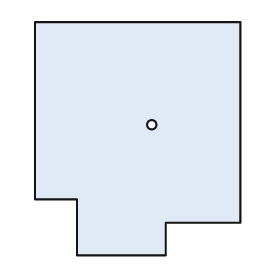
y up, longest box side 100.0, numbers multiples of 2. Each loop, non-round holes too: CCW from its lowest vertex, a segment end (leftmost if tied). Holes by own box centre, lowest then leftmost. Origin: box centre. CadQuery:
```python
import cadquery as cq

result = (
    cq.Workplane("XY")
    .moveTo(-26.0, -50.0)
    .lineTo(12.0, -50.0)
    .lineTo(12.0, -36.0)
    .lineTo(44.0, -36.0)
    .lineTo(44.0, 50.0)
    .lineTo(-44.0, 50.0)
    .lineTo(-44.0, -26.0)
    .lineTo(-26.0, -26.0)
    .close()
    .moveTo(6.0, 6.0)
    .circle(2.0)
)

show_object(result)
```